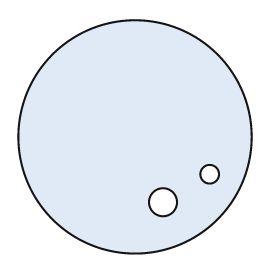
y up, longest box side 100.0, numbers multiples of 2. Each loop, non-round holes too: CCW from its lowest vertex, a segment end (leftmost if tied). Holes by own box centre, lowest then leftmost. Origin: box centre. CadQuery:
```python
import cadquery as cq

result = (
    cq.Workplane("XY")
    .moveTo(0.0, 0.0)
    .circle(50.0)
    .moveTo(12.0, -28.0)
    .circle(6.0)
    .moveTo(32.0, -16.0)
    .circle(4.0)
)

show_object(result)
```